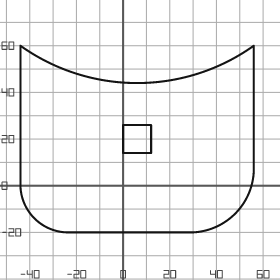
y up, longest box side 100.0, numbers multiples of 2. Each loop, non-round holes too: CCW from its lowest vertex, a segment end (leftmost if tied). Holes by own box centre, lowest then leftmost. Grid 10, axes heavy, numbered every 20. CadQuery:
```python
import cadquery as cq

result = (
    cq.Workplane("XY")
    .moveTo(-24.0, -20.0)
    .lineTo(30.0, -20.0)
    .threePointArc((48.0, -12.0), (56.0, 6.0))
    .lineTo(56.0, 60.0)
    .threePointArc((6.0, 44.0), (-44.0, 60.0))
    .lineTo(-44.0, 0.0)
    .threePointArc((-38.0, -14.0), (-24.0, -20.0))
    .close()
    .moveTo(0.0, 14.0)
    .lineTo(12.0, 14.0)
    .lineTo(12.0, 26.0)
    .lineTo(0.0, 26.0)
    .close()
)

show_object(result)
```